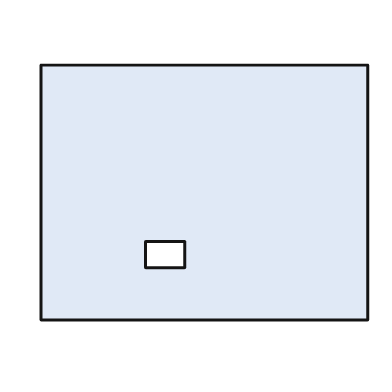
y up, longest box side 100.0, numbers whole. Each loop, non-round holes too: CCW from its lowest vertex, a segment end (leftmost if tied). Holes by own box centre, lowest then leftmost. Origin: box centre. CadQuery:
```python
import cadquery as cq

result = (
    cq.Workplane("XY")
    .moveTo(-50.0, -39.0)
    .lineTo(50.0, -39.0)
    .lineTo(50.0, 39.0)
    .lineTo(-50.0, 39.0)
    .close()
    .moveTo(-18.0, -23.0)
    .lineTo(-6.0, -23.0)
    .lineTo(-6.0, -15.0)
    .lineTo(-18.0, -15.0)
    .close()
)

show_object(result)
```